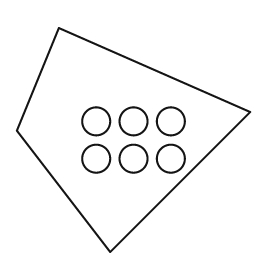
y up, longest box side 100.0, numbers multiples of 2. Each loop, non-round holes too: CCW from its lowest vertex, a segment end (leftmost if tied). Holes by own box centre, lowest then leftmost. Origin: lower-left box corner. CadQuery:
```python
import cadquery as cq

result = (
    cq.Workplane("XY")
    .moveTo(40.0, 0.0)
    .lineTo(100.0, 60.0)
    .lineTo(18.0, 96.0)
    .lineTo(0.0, 52.0)
    .close()
    .moveTo(34.0, 40.0)
    .circle(6.0)
    .moveTo(50.0, 40.0)
    .circle(6.0)
    .moveTo(66.0, 40.0)
    .circle(6.0)
    .moveTo(34.0, 56.0)
    .circle(6.0)
    .moveTo(50.0, 56.0)
    .circle(6.0)
    .moveTo(66.0, 56.0)
    .circle(6.0)
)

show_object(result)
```